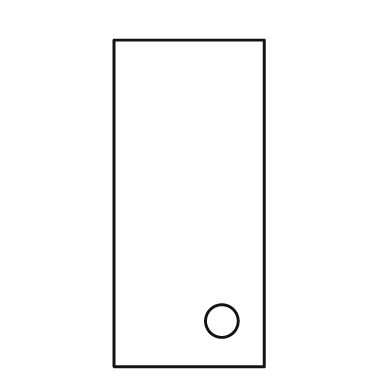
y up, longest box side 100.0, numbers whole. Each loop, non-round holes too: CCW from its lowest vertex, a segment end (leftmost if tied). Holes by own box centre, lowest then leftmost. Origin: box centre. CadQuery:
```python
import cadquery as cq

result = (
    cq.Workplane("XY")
    .moveTo(-23.0, -50.0)
    .lineTo(23.0, -50.0)
    .lineTo(23.0, 50.0)
    .lineTo(-23.0, 50.0)
    .close()
    .moveTo(10.0, -36.0)
    .circle(5.0)
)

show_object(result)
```